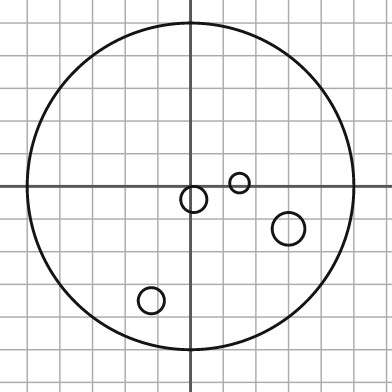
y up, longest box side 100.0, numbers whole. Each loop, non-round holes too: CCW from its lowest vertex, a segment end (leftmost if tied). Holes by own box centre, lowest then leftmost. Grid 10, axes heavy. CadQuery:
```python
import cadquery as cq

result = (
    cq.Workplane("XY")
    .moveTo(0.0, 0.0)
    .circle(50.0)
    .moveTo(-12.0, -35.0)
    .circle(4.0)
    .moveTo(30.0, -13.0)
    .circle(5.0)
    .moveTo(1.0, -4.0)
    .circle(4.0)
    .moveTo(15.0, 1.0)
    .circle(3.0)
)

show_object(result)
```